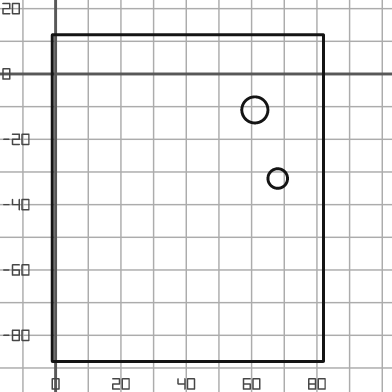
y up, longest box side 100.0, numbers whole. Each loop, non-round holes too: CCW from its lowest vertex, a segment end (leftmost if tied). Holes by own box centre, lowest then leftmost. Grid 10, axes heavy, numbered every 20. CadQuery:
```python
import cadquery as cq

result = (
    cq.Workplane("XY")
    .moveTo(-1.0, -88.0)
    .lineTo(82.0, -88.0)
    .lineTo(82.0, 12.0)
    .lineTo(-1.0, 12.0)
    .close()
    .moveTo(68.0, -32.0)
    .circle(3.0)
    .moveTo(61.0, -11.0)
    .circle(4.0)
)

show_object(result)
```